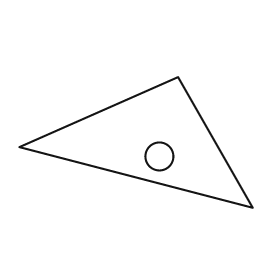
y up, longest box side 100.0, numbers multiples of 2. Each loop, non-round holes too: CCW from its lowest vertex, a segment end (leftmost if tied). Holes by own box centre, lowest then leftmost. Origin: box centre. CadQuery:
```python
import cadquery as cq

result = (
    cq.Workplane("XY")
    .moveTo(50.0, -28.0)
    .lineTo(18.0, 28.0)
    .lineTo(-50.0, -2.0)
    .close()
    .moveTo(10.0, -6.0)
    .circle(6.0)
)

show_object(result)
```